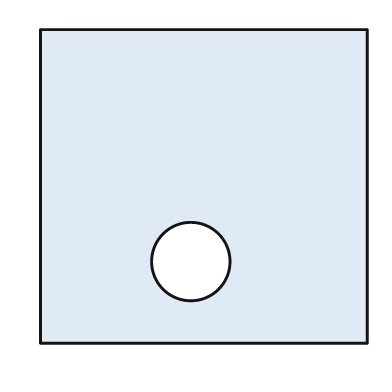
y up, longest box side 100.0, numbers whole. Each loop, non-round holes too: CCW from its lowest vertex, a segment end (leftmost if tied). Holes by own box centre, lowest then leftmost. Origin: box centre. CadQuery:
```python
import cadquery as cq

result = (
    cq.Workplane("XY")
    .moveTo(-50.0, -48.0)
    .lineTo(50.0, -48.0)
    .lineTo(50.0, 48.0)
    .lineTo(-50.0, 48.0)
    .close()
    .moveTo(-4.0, -23.0)
    .circle(12.0)
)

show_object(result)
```